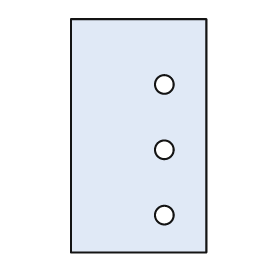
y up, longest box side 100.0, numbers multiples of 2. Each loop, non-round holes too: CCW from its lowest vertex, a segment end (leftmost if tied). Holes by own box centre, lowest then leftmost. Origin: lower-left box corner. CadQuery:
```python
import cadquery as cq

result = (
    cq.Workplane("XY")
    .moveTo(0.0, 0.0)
    .lineTo(58.0, 0.0)
    .lineTo(58.0, 100.0)
    .lineTo(0.0, 100.0)
    .close()
    .moveTo(40.0, 16.0)
    .circle(4.0)
    .moveTo(40.0, 44.0)
    .circle(4.0)
    .moveTo(40.0, 72.0)
    .circle(4.0)
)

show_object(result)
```